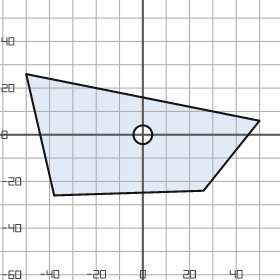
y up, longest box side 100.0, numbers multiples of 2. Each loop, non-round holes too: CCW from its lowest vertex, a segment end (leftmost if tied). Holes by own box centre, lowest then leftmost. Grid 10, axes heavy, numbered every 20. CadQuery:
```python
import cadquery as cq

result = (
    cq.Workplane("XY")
    .moveTo(-38.0, -26.0)
    .lineTo(26.0, -24.0)
    .lineTo(50.0, 6.0)
    .lineTo(-50.0, 26.0)
    .close()
    .moveTo(0.0, 0.0)
    .circle(4.0)
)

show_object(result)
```